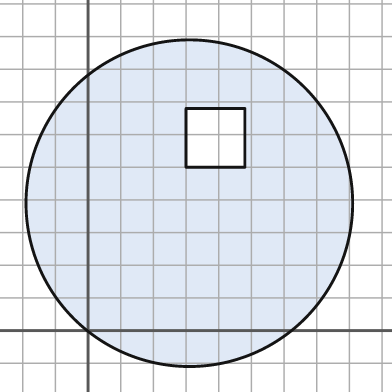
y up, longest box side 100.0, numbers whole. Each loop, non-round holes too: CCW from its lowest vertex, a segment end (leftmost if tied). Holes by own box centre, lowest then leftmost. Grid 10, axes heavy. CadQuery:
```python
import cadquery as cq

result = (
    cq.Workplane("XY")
    .moveTo(31.0, 39.0)
    .circle(50.0)
    .moveTo(30.0, 50.0)
    .lineTo(48.0, 50.0)
    .lineTo(48.0, 68.0)
    .lineTo(30.0, 68.0)
    .close()
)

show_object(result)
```